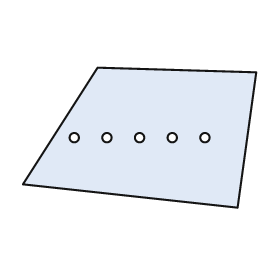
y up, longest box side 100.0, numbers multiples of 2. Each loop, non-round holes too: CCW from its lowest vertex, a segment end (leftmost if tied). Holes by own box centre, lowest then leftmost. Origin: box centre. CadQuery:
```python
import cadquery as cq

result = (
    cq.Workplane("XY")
    .moveTo(42.0, -30.0)
    .lineTo(50.0, 28.0)
    .lineTo(-18.0, 30.0)
    .lineTo(-50.0, -20.0)
    .close()
    .moveTo(-28.0, 0.0)
    .circle(2.0)
    .moveTo(-14.0, 0.0)
    .circle(2.0)
    .moveTo(0.0, 0.0)
    .circle(2.0)
    .moveTo(14.0, 0.0)
    .circle(2.0)
    .moveTo(28.0, 0.0)
    .circle(2.0)
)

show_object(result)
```